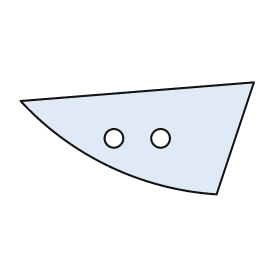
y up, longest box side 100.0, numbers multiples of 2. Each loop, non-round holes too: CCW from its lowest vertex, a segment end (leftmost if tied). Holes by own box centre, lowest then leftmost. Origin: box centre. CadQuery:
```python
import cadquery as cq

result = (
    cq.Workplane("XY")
    .moveTo(34.0, -24.0)
    .lineTo(50.0, 24.0)
    .lineTo(-50.0, 16.0)
    .threePointArc((-12.0, -12.0), (34.0, -24.0))
    .close()
    .moveTo(-10.0, 0.0)
    .circle(4.0)
    .moveTo(10.0, 0.0)
    .circle(4.0)
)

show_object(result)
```